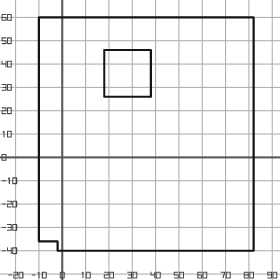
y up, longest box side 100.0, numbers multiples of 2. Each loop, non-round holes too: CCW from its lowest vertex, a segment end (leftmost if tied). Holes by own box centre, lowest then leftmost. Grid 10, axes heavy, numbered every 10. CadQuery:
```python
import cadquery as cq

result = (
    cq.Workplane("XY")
    .moveTo(-2.0, -40.0)
    .lineTo(82.0, -40.0)
    .lineTo(82.0, 60.0)
    .lineTo(-10.0, 60.0)
    .lineTo(-10.0, -36.0)
    .lineTo(-2.0, -36.0)
    .close()
    .moveTo(18.0, 26.0)
    .lineTo(38.0, 26.0)
    .lineTo(38.0, 46.0)
    .lineTo(18.0, 46.0)
    .close()
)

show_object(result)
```